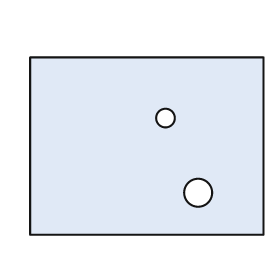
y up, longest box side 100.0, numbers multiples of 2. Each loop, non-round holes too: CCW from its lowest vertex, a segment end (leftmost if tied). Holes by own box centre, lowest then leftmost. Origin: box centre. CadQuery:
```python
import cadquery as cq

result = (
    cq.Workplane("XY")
    .moveTo(-50.0, -38.0)
    .lineTo(50.0, -38.0)
    .lineTo(50.0, 38.0)
    .lineTo(-50.0, 38.0)
    .close()
    .moveTo(22.0, -20.0)
    .circle(6.0)
    .moveTo(8.0, 12.0)
    .circle(4.0)
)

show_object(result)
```